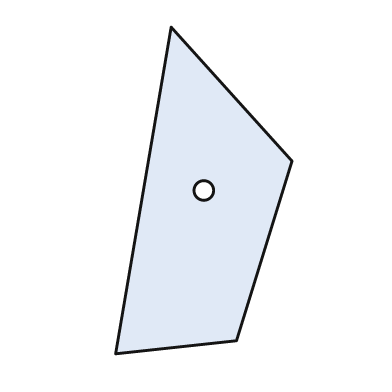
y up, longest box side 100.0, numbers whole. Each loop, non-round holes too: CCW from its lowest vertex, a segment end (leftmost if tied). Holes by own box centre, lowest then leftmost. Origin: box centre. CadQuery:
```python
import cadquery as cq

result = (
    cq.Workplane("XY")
    .moveTo(-27.0, -50.0)
    .lineTo(10.0, -46.0)
    .lineTo(27.0, 9.0)
    .lineTo(-10.0, 50.0)
    .close()
    .moveTo(0.0, 0.0)
    .circle(3.0)
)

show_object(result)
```